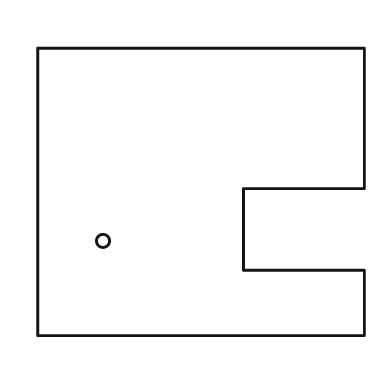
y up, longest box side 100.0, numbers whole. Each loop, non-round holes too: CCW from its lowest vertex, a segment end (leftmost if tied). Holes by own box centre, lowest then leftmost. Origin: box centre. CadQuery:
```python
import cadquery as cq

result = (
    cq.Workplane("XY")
    .moveTo(-50.0, -44.0)
    .lineTo(50.0, -44.0)
    .lineTo(50.0, -24.0)
    .lineTo(13.0, -24.0)
    .lineTo(13.0, 1.0)
    .lineTo(50.0, 1.0)
    .lineTo(50.0, 44.0)
    .lineTo(-50.0, 44.0)
    .close()
    .moveTo(-30.0, -15.0)
    .circle(2.0)
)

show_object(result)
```